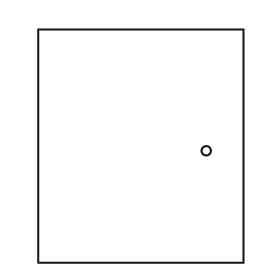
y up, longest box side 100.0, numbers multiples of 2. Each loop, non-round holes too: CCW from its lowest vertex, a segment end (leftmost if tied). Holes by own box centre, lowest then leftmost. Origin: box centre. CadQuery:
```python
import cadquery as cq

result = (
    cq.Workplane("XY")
    .moveTo(-44.0, -50.0)
    .lineTo(44.0, -50.0)
    .lineTo(44.0, 50.0)
    .lineTo(-44.0, 50.0)
    .close()
    .moveTo(28.0, -2.0)
    .circle(2.0)
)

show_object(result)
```